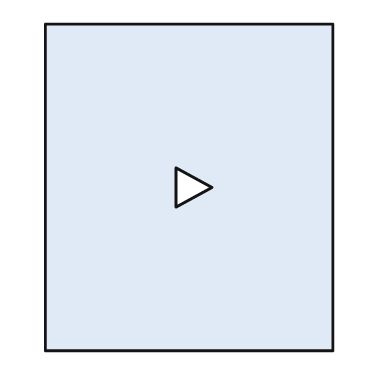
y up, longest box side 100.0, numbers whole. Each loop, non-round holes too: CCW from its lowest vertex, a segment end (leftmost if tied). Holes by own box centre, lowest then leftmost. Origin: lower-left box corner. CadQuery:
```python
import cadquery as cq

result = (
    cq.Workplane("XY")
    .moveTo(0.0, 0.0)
    .lineTo(88.0, 0.0)
    .lineTo(88.0, 100.0)
    .lineTo(0.0, 100.0)
    .close()
    .moveTo(40.0, 44.0)
    .lineTo(51.0, 50.0)
    .lineTo(40.0, 56.0)
    .close()
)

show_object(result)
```